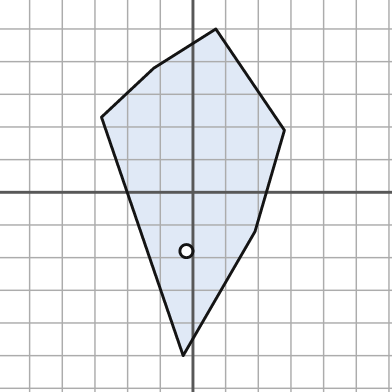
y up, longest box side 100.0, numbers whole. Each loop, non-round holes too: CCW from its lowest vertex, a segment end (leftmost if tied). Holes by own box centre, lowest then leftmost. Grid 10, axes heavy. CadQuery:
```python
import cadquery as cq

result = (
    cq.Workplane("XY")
    .moveTo(-3.0, -50.0)
    .lineTo(19.0, -12.0)
    .lineTo(28.0, 19.0)
    .lineTo(7.0, 50.0)
    .lineTo(-12.0, 38.0)
    .lineTo(-28.0, 23.0)
    .close()
    .moveTo(-2.0, -18.0)
    .circle(2.0)
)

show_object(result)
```